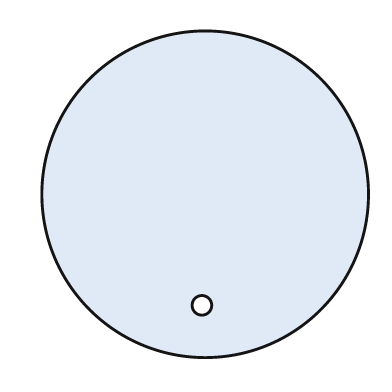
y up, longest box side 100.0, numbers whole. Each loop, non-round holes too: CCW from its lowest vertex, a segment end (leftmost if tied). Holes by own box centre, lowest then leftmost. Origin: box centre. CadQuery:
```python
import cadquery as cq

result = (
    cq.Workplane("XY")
    .moveTo(0.0, 0.0)
    .circle(50.0)
    .moveTo(-1.0, -34.0)
    .circle(3.0)
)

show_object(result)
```